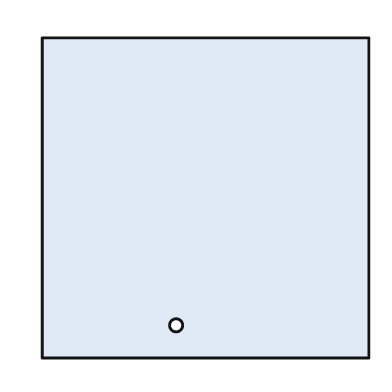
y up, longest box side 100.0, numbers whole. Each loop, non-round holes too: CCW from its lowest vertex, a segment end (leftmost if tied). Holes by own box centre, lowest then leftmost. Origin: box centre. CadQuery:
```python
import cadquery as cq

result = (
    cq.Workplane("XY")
    .moveTo(-50.0, -49.0)
    .lineTo(50.0, -49.0)
    .lineTo(50.0, 49.0)
    .lineTo(-50.0, 49.0)
    .close()
    .moveTo(-9.0, -39.0)
    .circle(2.0)
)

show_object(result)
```